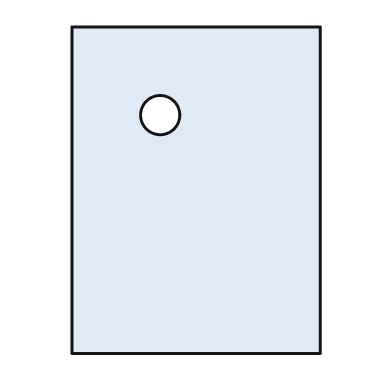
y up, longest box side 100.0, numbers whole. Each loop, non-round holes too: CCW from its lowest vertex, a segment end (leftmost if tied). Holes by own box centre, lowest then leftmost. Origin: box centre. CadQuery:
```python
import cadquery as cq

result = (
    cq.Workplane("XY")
    .moveTo(-38.0, -50.0)
    .lineTo(38.0, -50.0)
    .lineTo(38.0, 50.0)
    .lineTo(-38.0, 50.0)
    .close()
    .moveTo(-11.0, 23.0)
    .circle(6.0)
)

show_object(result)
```